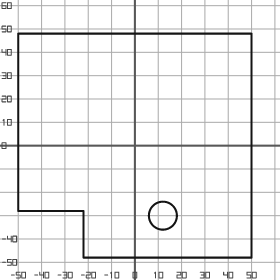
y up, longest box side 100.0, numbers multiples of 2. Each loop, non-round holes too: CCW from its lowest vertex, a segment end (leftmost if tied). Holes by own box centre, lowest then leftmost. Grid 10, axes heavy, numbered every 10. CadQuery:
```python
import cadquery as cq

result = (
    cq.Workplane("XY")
    .moveTo(-22.0, -48.0)
    .lineTo(50.0, -48.0)
    .lineTo(50.0, 48.0)
    .lineTo(-50.0, 48.0)
    .lineTo(-50.0, -28.0)
    .lineTo(-22.0, -28.0)
    .close()
    .moveTo(12.0, -30.0)
    .circle(6.0)
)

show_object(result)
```